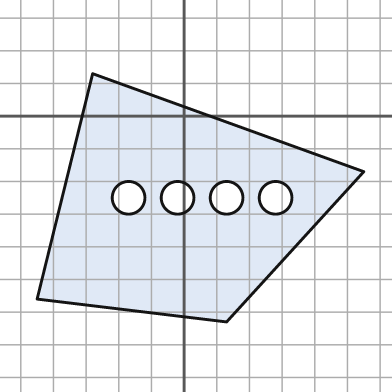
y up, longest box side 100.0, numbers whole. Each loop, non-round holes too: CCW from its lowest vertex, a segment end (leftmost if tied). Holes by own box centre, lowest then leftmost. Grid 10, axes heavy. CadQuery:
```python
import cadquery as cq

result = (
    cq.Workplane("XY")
    .moveTo(13.0, -63.0)
    .lineTo(55.0, -17.0)
    .lineTo(-28.0, 13.0)
    .lineTo(-45.0, -56.0)
    .close()
    .moveTo(-17.0, -25.0)
    .circle(5.0)
    .moveTo(-2.0, -25.0)
    .circle(5.0)
    .moveTo(13.0, -25.0)
    .circle(5.0)
    .moveTo(28.0, -25.0)
    .circle(5.0)
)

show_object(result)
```